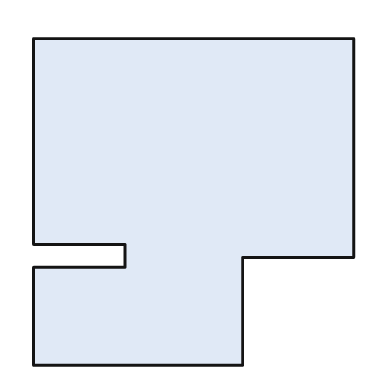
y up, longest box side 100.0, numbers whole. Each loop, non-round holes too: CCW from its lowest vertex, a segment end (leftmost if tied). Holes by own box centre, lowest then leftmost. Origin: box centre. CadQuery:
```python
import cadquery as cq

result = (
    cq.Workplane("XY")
    .moveTo(-49.0, -50.0)
    .lineTo(15.0, -50.0)
    .lineTo(15.0, -17.0)
    .lineTo(49.0, -17.0)
    .lineTo(49.0, 50.0)
    .lineTo(-49.0, 50.0)
    .lineTo(-49.0, -13.0)
    .lineTo(-21.0, -13.0)
    .lineTo(-21.0, -20.0)
    .lineTo(-49.0, -20.0)
    .close()
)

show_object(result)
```